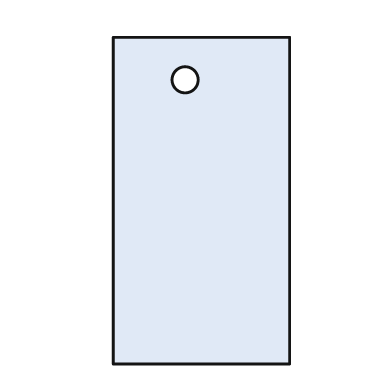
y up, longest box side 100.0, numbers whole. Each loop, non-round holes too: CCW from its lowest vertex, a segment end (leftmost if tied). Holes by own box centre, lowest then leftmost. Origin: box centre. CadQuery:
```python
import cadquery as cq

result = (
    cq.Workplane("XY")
    .moveTo(-27.0, -50.0)
    .lineTo(27.0, -50.0)
    .lineTo(27.0, 50.0)
    .lineTo(-27.0, 50.0)
    .close()
    .moveTo(-5.0, 37.0)
    .circle(4.0)
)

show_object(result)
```